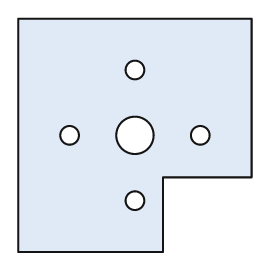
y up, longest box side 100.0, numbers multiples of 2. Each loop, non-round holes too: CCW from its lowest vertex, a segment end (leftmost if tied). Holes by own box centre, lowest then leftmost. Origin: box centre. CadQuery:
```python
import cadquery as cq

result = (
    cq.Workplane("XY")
    .moveTo(-50.0, -50.0)
    .lineTo(12.0, -50.0)
    .lineTo(12.0, -18.0)
    .lineTo(50.0, -18.0)
    .lineTo(50.0, 50.0)
    .lineTo(-50.0, 50.0)
    .close()
    .moveTo(0.0, -28.0)
    .circle(4.0)
    .moveTo(-28.0, 0.0)
    .circle(4.0)
    .moveTo(0.0, 0.0)
    .circle(8.0)
    .moveTo(28.0, 0.0)
    .circle(4.0)
    .moveTo(0.0, 28.0)
    .circle(4.0)
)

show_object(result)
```